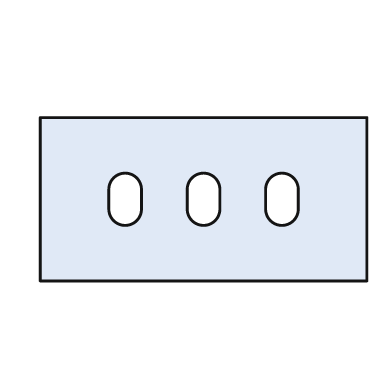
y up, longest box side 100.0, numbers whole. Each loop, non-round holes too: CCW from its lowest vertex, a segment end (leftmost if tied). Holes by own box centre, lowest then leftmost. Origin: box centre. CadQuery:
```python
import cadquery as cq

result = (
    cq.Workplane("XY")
    .moveTo(-50.0, -25.0)
    .lineTo(50.0, -25.0)
    .lineTo(50.0, 25.0)
    .lineTo(-50.0, 25.0)
    .close()
    .moveTo(-29.0, -3.0)
    .threePointArc((-24.0, -8.0), (-19.0, -3.0))
    .lineTo(-19.0, 3.0)
    .threePointArc((-24.0, 8.0), (-29.0, 3.0))
    .close()
    .moveTo(-5.0, -3.0)
    .threePointArc((0.0, -8.0), (5.0, -3.0))
    .lineTo(5.0, 3.0)
    .threePointArc((0.0, 8.0), (-5.0, 3.0))
    .close()
    .moveTo(19.0, -3.0)
    .threePointArc((24.0, -8.0), (29.0, -3.0))
    .lineTo(29.0, 3.0)
    .threePointArc((24.0, 8.0), (19.0, 3.0))
    .close()
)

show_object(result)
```